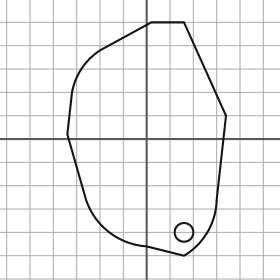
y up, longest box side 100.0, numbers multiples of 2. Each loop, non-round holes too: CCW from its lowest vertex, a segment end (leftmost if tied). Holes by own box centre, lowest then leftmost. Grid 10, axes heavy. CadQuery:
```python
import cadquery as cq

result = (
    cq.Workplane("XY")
    .moveTo(16.0, -50.0)
    .threePointArc((26.0, -40.0), (30.0, -26.0))
    .lineTo(34.0, 10.0)
    .lineTo(16.0, 50.0)
    .lineTo(2.0, 50.0)
    .lineTo(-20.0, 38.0)
    .threePointArc((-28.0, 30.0), (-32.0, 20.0))
    .lineTo(-34.0, 2.0)
    .lineTo(-26.0, -26.0)
    .threePointArc((-16.0, -40.0), (0.0, -46.0))
    .close()
    .moveTo(16.0, -40.0)
    .circle(4.0)
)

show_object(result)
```